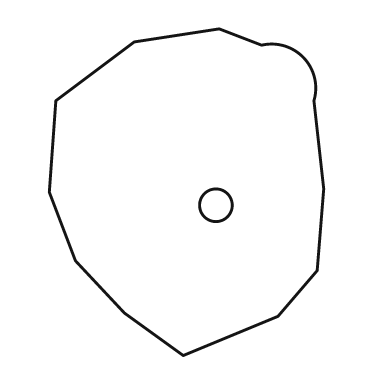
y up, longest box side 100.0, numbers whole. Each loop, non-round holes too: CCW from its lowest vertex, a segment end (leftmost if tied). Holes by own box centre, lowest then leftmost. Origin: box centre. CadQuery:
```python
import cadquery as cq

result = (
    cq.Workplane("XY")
    .moveTo(-1.0, -50.0)
    .lineTo(28.0, -38.0)
    .lineTo(40.0, -24.0)
    .lineTo(42.0, 1.0)
    .lineTo(39.0, 28.0)
    .threePointArc((36.0, 41.0), (23.0, 45.0))
    .lineTo(10.0, 50.0)
    .lineTo(-16.0, 46.0)
    .lineTo(-40.0, 28.0)
    .lineTo(-42.0, 0.0)
    .lineTo(-34.0, -21.0)
    .lineTo(-19.0, -37.0)
    .close()
    .moveTo(9.0, -4.0)
    .circle(5.0)
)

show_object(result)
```